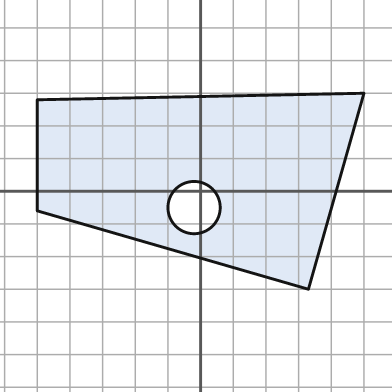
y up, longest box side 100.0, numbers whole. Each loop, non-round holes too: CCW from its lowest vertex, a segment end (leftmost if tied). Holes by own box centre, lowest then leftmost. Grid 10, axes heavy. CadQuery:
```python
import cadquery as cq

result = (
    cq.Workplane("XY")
    .moveTo(33.0, -30.0)
    .lineTo(50.0, 30.0)
    .lineTo(-50.0, 28.0)
    .lineTo(-50.0, -6.0)
    .close()
    .moveTo(-2.0, -5.0)
    .circle(8.0)
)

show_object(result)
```